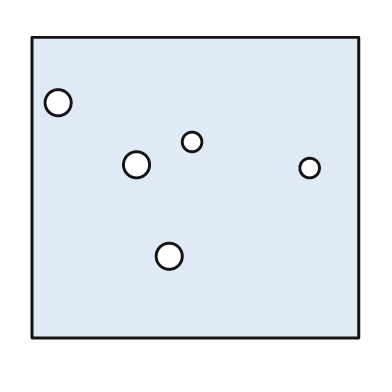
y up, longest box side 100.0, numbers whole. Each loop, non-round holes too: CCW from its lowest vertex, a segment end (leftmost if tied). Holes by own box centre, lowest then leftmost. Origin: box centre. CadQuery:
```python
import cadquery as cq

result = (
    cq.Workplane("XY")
    .moveTo(-50.0, -46.0)
    .lineTo(50.0, -46.0)
    .lineTo(50.0, 46.0)
    .lineTo(-50.0, 46.0)
    .close()
    .moveTo(-8.0, -21.0)
    .circle(4.0)
    .moveTo(35.0, 6.0)
    .circle(3.0)
    .moveTo(-18.0, 7.0)
    .circle(4.0)
    .moveTo(-1.0, 14.0)
    .circle(3.0)
    .moveTo(-42.0, 26.0)
    .circle(4.0)
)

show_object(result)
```